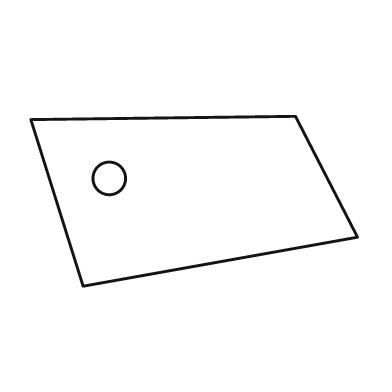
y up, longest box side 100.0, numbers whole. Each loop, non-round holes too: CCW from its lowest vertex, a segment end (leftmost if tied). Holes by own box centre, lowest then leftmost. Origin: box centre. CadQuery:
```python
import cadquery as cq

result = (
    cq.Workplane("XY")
    .moveTo(-34.0, -26.0)
    .lineTo(50.0, -11.0)
    .lineTo(31.0, 26.0)
    .lineTo(-50.0, 25.0)
    .close()
    .moveTo(-26.0, 7.0)
    .circle(5.0)
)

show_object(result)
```